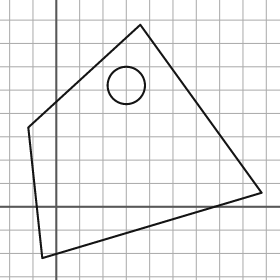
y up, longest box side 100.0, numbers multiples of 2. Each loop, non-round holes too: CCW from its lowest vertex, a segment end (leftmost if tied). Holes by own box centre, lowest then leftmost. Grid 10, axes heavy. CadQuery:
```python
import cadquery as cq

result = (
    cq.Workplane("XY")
    .moveTo(-6.0, -22.0)
    .lineTo(88.0, 6.0)
    .lineTo(36.0, 78.0)
    .lineTo(-12.0, 34.0)
    .close()
    .moveTo(30.0, 52.0)
    .circle(8.0)
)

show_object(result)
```